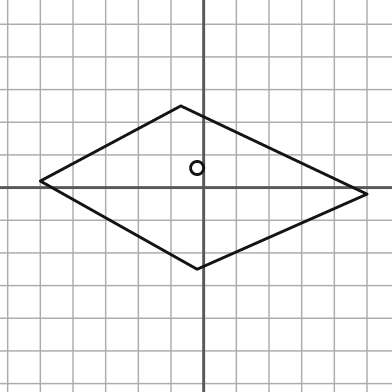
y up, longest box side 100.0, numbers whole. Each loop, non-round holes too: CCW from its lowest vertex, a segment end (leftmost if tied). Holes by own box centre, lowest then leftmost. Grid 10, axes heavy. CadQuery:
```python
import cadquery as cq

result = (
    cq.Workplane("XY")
    .moveTo(-2.0, -25.0)
    .lineTo(50.0, -2.0)
    .lineTo(-7.0, 25.0)
    .lineTo(-50.0, 2.0)
    .close()
    .moveTo(-2.0, 6.0)
    .circle(2.0)
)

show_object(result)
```